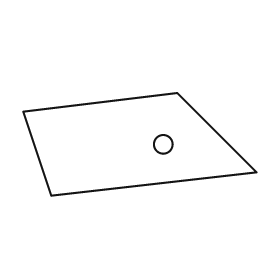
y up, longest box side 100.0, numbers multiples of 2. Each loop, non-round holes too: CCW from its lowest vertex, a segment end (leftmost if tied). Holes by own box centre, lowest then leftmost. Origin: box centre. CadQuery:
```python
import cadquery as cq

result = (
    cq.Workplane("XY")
    .moveTo(-38.0, -22.0)
    .lineTo(50.0, -12.0)
    .lineTo(16.0, 22.0)
    .lineTo(-50.0, 14.0)
    .close()
    .moveTo(10.0, 0.0)
    .circle(4.0)
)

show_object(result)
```